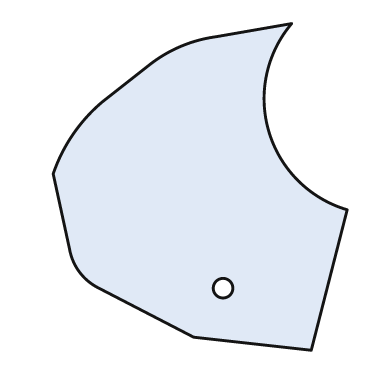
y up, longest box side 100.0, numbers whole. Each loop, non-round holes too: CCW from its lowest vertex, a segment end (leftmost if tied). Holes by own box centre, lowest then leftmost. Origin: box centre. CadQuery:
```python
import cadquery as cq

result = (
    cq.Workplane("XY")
    .moveTo(34.0, -50.0)
    .lineTo(45.0, -7.0)
    .threePointArc((21.0, 17.0), (28.0, 50.0))
    .lineTo(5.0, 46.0)
    .threePointArc((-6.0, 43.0), (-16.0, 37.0))
    .lineTo(-30.0, 26.0)
    .threePointArc((-39.0, 16.0), (-45.0, 4.0))
    .lineTo(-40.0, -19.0)
    .threePointArc((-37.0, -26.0), (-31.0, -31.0))
    .lineTo(-2.0, -46.0)
    .close()
    .moveTo(7.0, -31.0)
    .circle(3.0)
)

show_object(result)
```